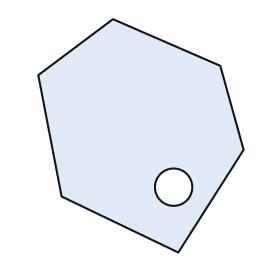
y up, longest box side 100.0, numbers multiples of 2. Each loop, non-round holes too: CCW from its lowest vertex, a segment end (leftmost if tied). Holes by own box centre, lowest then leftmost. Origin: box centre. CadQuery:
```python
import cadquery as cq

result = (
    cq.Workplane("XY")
    .moveTo(16.0, -50.0)
    .lineTo(44.0, -6.0)
    .lineTo(34.0, 30.0)
    .lineTo(-12.0, 50.0)
    .lineTo(-44.0, 26.0)
    .lineTo(-34.0, -26.0)
    .close()
    .moveTo(14.0, -22.0)
    .circle(8.0)
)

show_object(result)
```